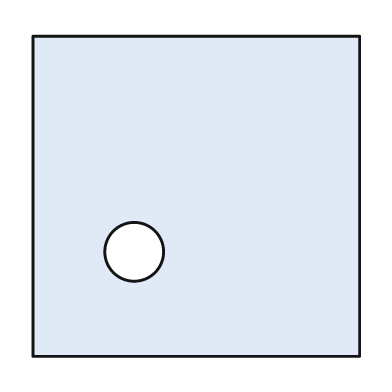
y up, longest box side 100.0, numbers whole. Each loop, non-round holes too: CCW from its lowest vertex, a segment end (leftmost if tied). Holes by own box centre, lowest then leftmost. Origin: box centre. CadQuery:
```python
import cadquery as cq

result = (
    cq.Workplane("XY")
    .moveTo(-50.0, -49.0)
    .lineTo(50.0, -49.0)
    .lineTo(50.0, 49.0)
    .lineTo(-50.0, 49.0)
    .close()
    .moveTo(-19.0, -17.0)
    .circle(9.0)
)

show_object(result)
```